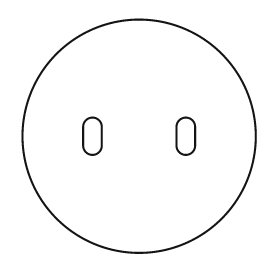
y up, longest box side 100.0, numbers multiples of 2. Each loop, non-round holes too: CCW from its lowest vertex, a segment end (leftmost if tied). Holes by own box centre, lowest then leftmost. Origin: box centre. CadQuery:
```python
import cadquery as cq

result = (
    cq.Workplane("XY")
    .moveTo(0.0, 0.0)
    .circle(50.0)
    .moveTo(-24.0, -4.0)
    .threePointArc((-20.0, -8.0), (-16.0, -4.0))
    .lineTo(-16.0, 4.0)
    .threePointArc((-20.0, 8.0), (-24.0, 4.0))
    .close()
    .moveTo(16.0, -4.0)
    .threePointArc((20.0, -8.0), (24.0, -4.0))
    .lineTo(24.0, 4.0)
    .threePointArc((20.0, 8.0), (16.0, 4.0))
    .close()
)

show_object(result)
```